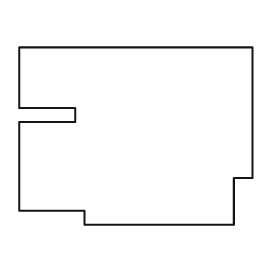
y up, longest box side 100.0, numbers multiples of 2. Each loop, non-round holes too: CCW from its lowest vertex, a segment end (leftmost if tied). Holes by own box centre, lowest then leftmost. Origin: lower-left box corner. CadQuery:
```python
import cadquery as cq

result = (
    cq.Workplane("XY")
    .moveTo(28.0, 0.0)
    .lineTo(92.0, 0.0)
    .lineTo(92.0, 20.0)
    .lineTo(100.0, 20.0)
    .lineTo(100.0, 76.0)
    .lineTo(0.0, 76.0)
    .lineTo(0.0, 50.0)
    .lineTo(24.0, 50.0)
    .lineTo(24.0, 44.0)
    .lineTo(0.0, 44.0)
    .lineTo(0.0, 6.0)
    .lineTo(28.0, 6.0)
    .close()
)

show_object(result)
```